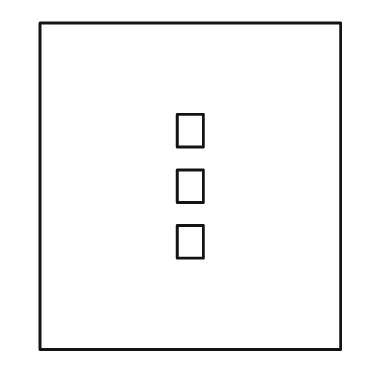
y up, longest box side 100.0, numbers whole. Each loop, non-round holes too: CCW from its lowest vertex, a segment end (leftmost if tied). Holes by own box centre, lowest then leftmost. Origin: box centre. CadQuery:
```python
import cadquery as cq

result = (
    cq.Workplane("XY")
    .moveTo(-46.0, -50.0)
    .lineTo(46.0, -50.0)
    .lineTo(46.0, 50.0)
    .lineTo(-46.0, 50.0)
    .close()
    .moveTo(-4.0, -22.0)
    .lineTo(4.0, -22.0)
    .lineTo(4.0, -12.0)
    .lineTo(-4.0, -12.0)
    .close()
    .moveTo(-4.0, -5.0)
    .lineTo(4.0, -5.0)
    .lineTo(4.0, 5.0)
    .lineTo(-4.0, 5.0)
    .close()
    .moveTo(-4.0, 12.0)
    .lineTo(4.0, 12.0)
    .lineTo(4.0, 22.0)
    .lineTo(-4.0, 22.0)
    .close()
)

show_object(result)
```